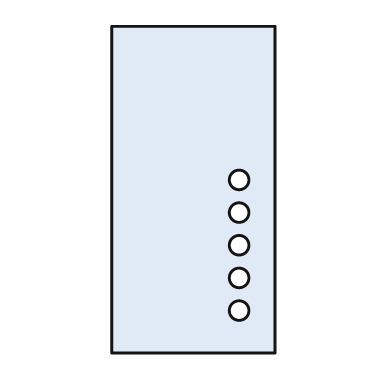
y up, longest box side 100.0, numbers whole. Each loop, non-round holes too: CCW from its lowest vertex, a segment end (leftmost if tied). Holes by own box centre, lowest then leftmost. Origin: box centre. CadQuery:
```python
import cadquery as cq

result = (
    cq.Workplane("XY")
    .moveTo(-25.0, -50.0)
    .lineTo(25.0, -50.0)
    .lineTo(25.0, 50.0)
    .lineTo(-25.0, 50.0)
    .close()
    .moveTo(14.0, -37.0)
    .circle(3.0)
    .moveTo(14.0, -27.0)
    .circle(3.0)
    .moveTo(14.0, -17.0)
    .circle(3.0)
    .moveTo(14.0, -7.0)
    .circle(3.0)
    .moveTo(14.0, 3.0)
    .circle(3.0)
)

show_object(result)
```